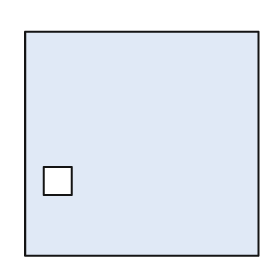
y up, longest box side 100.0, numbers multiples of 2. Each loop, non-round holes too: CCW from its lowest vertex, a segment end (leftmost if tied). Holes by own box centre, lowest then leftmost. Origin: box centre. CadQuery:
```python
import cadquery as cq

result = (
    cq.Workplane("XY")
    .moveTo(-50.0, -48.0)
    .lineTo(50.0, -48.0)
    .lineTo(50.0, 48.0)
    .lineTo(-50.0, 48.0)
    .close()
    .moveTo(-42.0, -22.0)
    .lineTo(-30.0, -22.0)
    .lineTo(-30.0, -10.0)
    .lineTo(-42.0, -10.0)
    .close()
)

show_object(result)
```